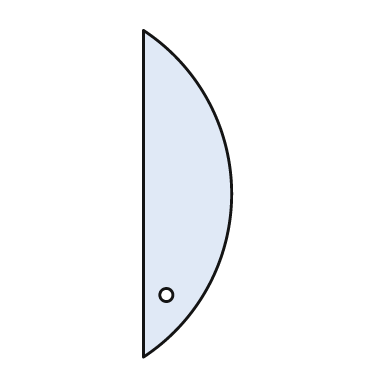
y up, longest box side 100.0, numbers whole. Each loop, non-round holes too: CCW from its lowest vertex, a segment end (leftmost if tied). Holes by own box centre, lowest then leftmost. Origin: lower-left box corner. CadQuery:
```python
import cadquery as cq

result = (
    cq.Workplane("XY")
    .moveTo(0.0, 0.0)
    .threePointArc((27.0, 50.0), (0.0, 100.0))
    .close()
    .moveTo(7.0, 19.0)
    .circle(2.0)
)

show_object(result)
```